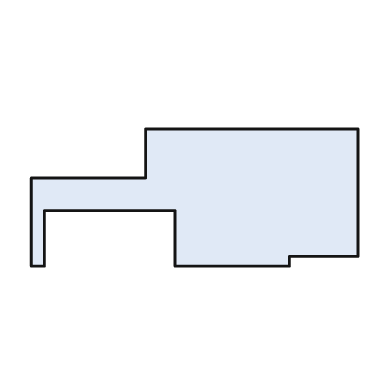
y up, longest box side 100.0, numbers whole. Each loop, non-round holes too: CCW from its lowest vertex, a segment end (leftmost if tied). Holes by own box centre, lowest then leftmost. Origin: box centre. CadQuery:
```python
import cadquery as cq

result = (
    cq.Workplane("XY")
    .moveTo(-50.0, -21.0)
    .lineTo(-46.0, -21.0)
    .lineTo(-46.0, -4.0)
    .lineTo(-6.0, -4.0)
    .lineTo(-6.0, -21.0)
    .lineTo(29.0, -21.0)
    .lineTo(29.0, -18.0)
    .lineTo(50.0, -18.0)
    .lineTo(50.0, 21.0)
    .lineTo(-15.0, 21.0)
    .lineTo(-15.0, 6.0)
    .lineTo(-50.0, 6.0)
    .close()
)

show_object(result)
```